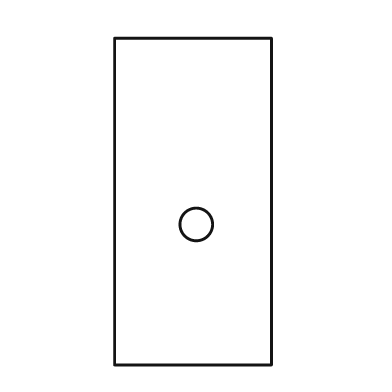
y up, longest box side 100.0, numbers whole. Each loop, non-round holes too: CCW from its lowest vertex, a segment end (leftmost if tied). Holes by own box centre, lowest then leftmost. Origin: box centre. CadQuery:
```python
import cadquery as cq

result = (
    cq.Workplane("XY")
    .moveTo(-24.0, -50.0)
    .lineTo(24.0, -50.0)
    .lineTo(24.0, 50.0)
    .lineTo(-24.0, 50.0)
    .close()
    .moveTo(1.0, -7.0)
    .circle(5.0)
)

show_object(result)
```